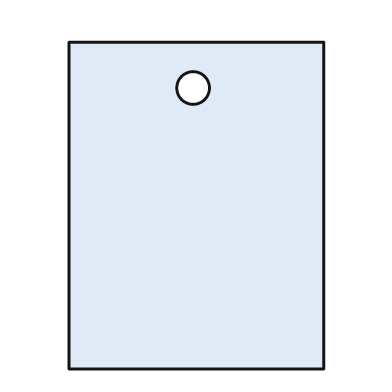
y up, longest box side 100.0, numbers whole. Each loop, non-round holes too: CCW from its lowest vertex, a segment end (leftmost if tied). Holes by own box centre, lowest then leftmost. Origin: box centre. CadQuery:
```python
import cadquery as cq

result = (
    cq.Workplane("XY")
    .moveTo(-39.0, -50.0)
    .lineTo(39.0, -50.0)
    .lineTo(39.0, 50.0)
    .lineTo(-39.0, 50.0)
    .close()
    .moveTo(-1.0, 36.0)
    .circle(5.0)
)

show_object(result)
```